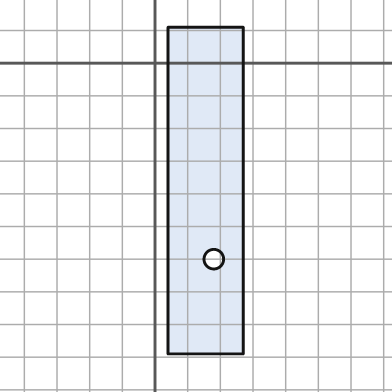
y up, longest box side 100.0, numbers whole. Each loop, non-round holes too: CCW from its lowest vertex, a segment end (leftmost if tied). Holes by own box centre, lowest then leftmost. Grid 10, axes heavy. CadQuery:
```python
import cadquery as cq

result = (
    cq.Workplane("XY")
    .moveTo(4.0, -89.0)
    .lineTo(27.0, -89.0)
    .lineTo(27.0, 11.0)
    .lineTo(4.0, 11.0)
    .close()
    .moveTo(18.0, -60.0)
    .circle(3.0)
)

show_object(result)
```